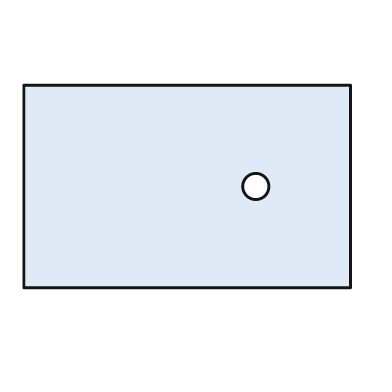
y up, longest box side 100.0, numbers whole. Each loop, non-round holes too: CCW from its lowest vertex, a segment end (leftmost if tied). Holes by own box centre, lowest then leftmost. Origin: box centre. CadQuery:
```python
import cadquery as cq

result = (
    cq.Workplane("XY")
    .moveTo(-50.0, -31.0)
    .lineTo(50.0, -31.0)
    .lineTo(50.0, 31.0)
    .lineTo(-50.0, 31.0)
    .close()
    .moveTo(21.0, 0.0)
    .circle(4.0)
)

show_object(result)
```